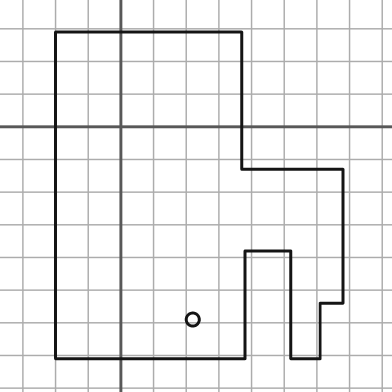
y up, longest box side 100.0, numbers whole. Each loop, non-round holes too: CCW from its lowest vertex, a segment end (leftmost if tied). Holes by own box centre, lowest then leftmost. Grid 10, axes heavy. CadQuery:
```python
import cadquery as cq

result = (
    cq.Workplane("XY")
    .moveTo(-20.0, -71.0)
    .lineTo(38.0, -71.0)
    .lineTo(38.0, -38.0)
    .lineTo(52.0, -38.0)
    .lineTo(52.0, -71.0)
    .lineTo(61.0, -71.0)
    .lineTo(61.0, -54.0)
    .lineTo(68.0, -54.0)
    .lineTo(68.0, -13.0)
    .lineTo(37.0, -13.0)
    .lineTo(37.0, 29.0)
    .lineTo(-20.0, 29.0)
    .close()
    .moveTo(22.0, -59.0)
    .circle(2.0)
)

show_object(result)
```